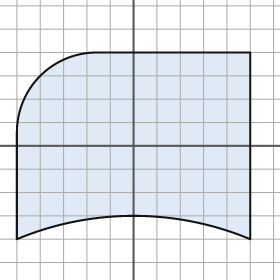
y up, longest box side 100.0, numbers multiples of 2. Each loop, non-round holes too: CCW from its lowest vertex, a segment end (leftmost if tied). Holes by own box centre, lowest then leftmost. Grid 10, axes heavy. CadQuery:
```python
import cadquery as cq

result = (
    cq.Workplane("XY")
    .moveTo(-50.0, -40.0)
    .threePointArc((0.0, -30.0), (50.0, -40.0))
    .lineTo(50.0, 40.0)
    .lineTo(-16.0, 40.0)
    .threePointArc((-40.0, 30.0), (-50.0, 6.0))
    .close()
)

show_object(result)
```